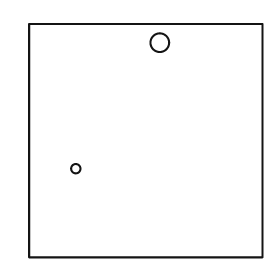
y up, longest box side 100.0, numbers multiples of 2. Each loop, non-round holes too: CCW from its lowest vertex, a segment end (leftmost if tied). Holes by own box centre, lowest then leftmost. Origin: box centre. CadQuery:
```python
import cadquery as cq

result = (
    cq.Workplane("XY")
    .moveTo(-50.0, -50.0)
    .lineTo(50.0, -50.0)
    .lineTo(50.0, 50.0)
    .lineTo(-50.0, 50.0)
    .close()
    .moveTo(-30.0, -12.0)
    .circle(2.0)
    .moveTo(6.0, 42.0)
    .circle(4.0)
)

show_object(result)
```